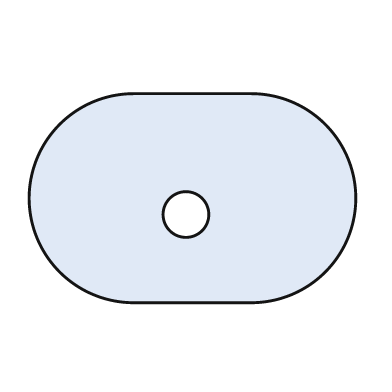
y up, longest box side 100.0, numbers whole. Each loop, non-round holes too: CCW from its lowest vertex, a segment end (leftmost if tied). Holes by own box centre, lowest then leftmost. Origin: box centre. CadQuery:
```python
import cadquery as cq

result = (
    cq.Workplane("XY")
    .moveTo(-18.0, -32.0)
    .lineTo(18.0, -32.0)
    .threePointArc((50.0, 0.0), (18.0, 32.0))
    .lineTo(-18.0, 32.0)
    .threePointArc((-50.0, 0.0), (-18.0, -32.0))
    .close()
    .moveTo(-2.0, -5.0)
    .circle(7.0)
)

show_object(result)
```